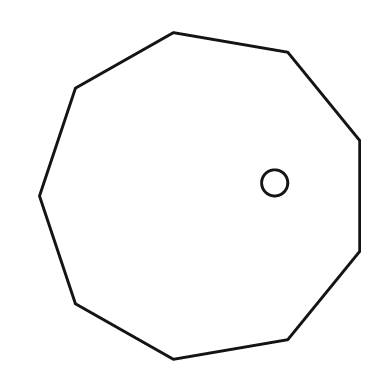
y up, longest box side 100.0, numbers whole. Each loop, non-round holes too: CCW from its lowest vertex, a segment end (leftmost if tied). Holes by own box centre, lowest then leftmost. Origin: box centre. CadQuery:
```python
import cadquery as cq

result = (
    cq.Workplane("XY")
    .moveTo(-8.0, -50.0)
    .lineTo(27.0, -44.0)
    .lineTo(49.0, -17.0)
    .lineTo(49.0, 17.0)
    .lineTo(27.0, 44.0)
    .lineTo(-8.0, 50.0)
    .lineTo(-38.0, 33.0)
    .lineTo(-49.0, 0.0)
    .lineTo(-38.0, -33.0)
    .close()
    .moveTo(23.0, 4.0)
    .circle(4.0)
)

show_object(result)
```